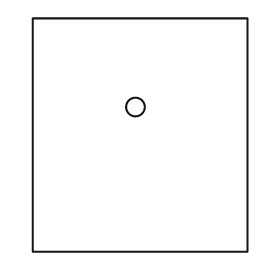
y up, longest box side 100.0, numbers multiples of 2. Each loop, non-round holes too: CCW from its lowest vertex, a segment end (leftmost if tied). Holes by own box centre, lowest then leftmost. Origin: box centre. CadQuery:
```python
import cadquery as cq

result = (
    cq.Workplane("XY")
    .moveTo(-46.0, -50.0)
    .lineTo(46.0, -50.0)
    .lineTo(46.0, 50.0)
    .lineTo(-46.0, 50.0)
    .close()
    .moveTo(-2.0, 12.0)
    .circle(4.0)
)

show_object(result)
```